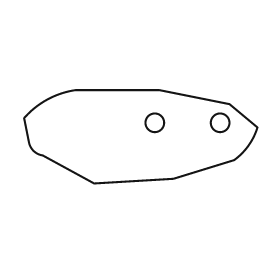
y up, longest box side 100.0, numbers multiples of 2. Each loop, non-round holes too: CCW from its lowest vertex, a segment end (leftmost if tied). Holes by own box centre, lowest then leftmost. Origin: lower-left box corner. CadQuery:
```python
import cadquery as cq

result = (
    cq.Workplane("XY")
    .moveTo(30.0, 0.0)
    .lineTo(64.0, 2.0)
    .lineTo(90.0, 10.0)
    .threePointArc((96.0, 16.0), (100.0, 24.0))
    .lineTo(88.0, 34.0)
    .lineTo(58.0, 40.0)
    .lineTo(22.0, 40.0)
    .threePointArc((10.0, 36.0), (0.0, 28.0))
    .lineTo(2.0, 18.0)
    .threePointArc((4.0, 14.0), (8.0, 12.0))
    .close()
    .moveTo(56.0, 26.0)
    .circle(4.0)
    .moveTo(84.0, 26.0)
    .circle(4.0)
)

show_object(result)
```